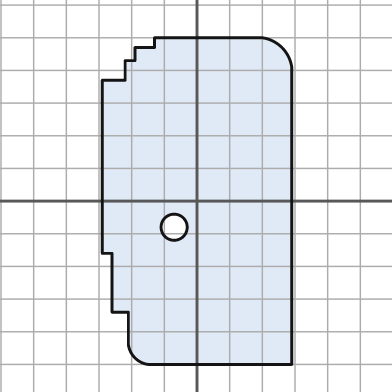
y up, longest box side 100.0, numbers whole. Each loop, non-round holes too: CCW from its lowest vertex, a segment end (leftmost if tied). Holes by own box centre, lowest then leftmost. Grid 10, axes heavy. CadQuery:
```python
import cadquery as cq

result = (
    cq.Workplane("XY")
    .moveTo(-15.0, -50.0)
    .lineTo(29.0, -50.0)
    .lineTo(29.0, 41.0)
    .threePointArc((26.0, 47.0), (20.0, 50.0))
    .lineTo(-13.0, 50.0)
    .lineTo(-13.0, 47.0)
    .lineTo(-19.0, 47.0)
    .lineTo(-19.0, 43.0)
    .lineTo(-22.0, 43.0)
    .lineTo(-22.0, 37.0)
    .lineTo(-29.0, 37.0)
    .lineTo(-29.0, -16.0)
    .lineTo(-26.0, -16.0)
    .lineTo(-26.0, -34.0)
    .lineTo(-21.0, -34.0)
    .lineTo(-21.0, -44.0)
    .threePointArc((-19.0, -48.0), (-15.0, -50.0))
    .close()
    .moveTo(-7.0, -8.0)
    .circle(4.0)
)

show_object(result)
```